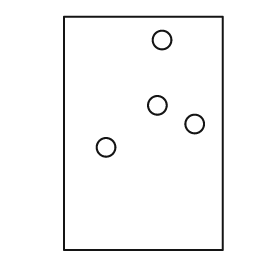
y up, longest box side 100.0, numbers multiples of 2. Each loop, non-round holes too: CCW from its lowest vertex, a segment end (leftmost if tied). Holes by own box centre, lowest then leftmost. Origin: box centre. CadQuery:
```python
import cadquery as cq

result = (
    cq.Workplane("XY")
    .moveTo(-34.0, -50.0)
    .lineTo(34.0, -50.0)
    .lineTo(34.0, 50.0)
    .lineTo(-34.0, 50.0)
    .close()
    .moveTo(-16.0, -6.0)
    .circle(4.0)
    .moveTo(22.0, 4.0)
    .circle(4.0)
    .moveTo(6.0, 12.0)
    .circle(4.0)
    .moveTo(8.0, 40.0)
    .circle(4.0)
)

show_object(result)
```